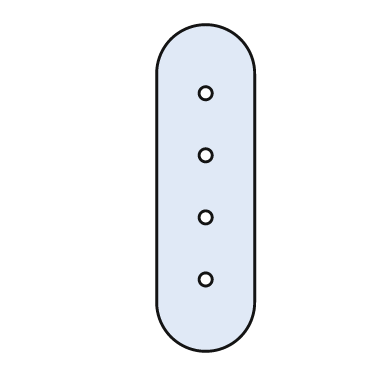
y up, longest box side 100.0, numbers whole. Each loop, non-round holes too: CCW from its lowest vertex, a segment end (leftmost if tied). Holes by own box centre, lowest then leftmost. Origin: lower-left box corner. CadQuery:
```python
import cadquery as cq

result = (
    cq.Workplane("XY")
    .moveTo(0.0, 15.0)
    .threePointArc((15.0, 0.0), (30.0, 15.0))
    .lineTo(30.0, 85.0)
    .threePointArc((15.0, 100.0), (0.0, 85.0))
    .close()
    .moveTo(15.0, 22.0)
    .circle(2.0)
    .moveTo(15.0, 41.0)
    .circle(2.0)
    .moveTo(15.0, 60.0)
    .circle(2.0)
    .moveTo(15.0, 79.0)
    .circle(2.0)
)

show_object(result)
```